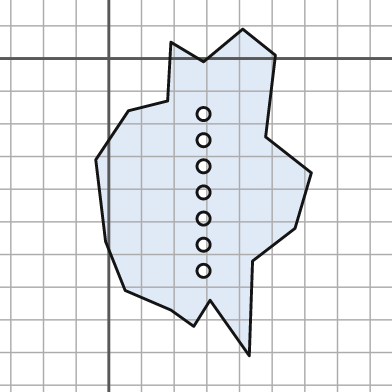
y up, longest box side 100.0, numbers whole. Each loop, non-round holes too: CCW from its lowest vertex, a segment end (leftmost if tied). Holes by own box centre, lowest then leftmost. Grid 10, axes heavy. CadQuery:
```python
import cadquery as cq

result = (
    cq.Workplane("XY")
    .moveTo(43.0, -91.0)
    .lineTo(44.0, -62.0)
    .lineTo(57.0, -52.0)
    .lineTo(62.0, -35.0)
    .lineTo(48.0, -24.0)
    .lineTo(51.0, 1.0)
    .lineTo(41.0, 9.0)
    .lineTo(29.0, -1.0)
    .lineTo(19.0, 5.0)
    .lineTo(18.0, -13.0)
    .lineTo(6.0, -16.0)
    .lineTo(-4.0, -31.0)
    .lineTo(-1.0, -56.0)
    .lineTo(5.0, -71.0)
    .lineTo(19.0, -77.0)
    .lineTo(26.0, -82.0)
    .lineTo(31.0, -74.0)
    .close()
    .moveTo(29.0, -65.0)
    .circle(2.0)
    .moveTo(29.0, -57.0)
    .circle(2.0)
    .moveTo(29.0, -49.0)
    .circle(2.0)
    .moveTo(29.0, -41.0)
    .circle(2.0)
    .moveTo(29.0, -33.0)
    .circle(2.0)
    .moveTo(29.0, -25.0)
    .circle(2.0)
    .moveTo(29.0, -17.0)
    .circle(2.0)
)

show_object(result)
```